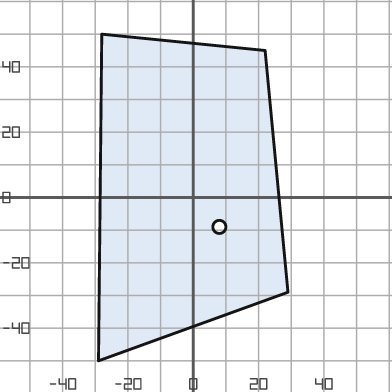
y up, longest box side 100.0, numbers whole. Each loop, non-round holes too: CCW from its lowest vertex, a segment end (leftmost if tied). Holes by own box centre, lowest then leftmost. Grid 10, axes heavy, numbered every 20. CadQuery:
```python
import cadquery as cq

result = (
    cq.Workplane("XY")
    .moveTo(-29.0, -50.0)
    .lineTo(29.0, -29.0)
    .lineTo(22.0, 45.0)
    .lineTo(-28.0, 50.0)
    .close()
    .moveTo(8.0, -9.0)
    .circle(2.0)
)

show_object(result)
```